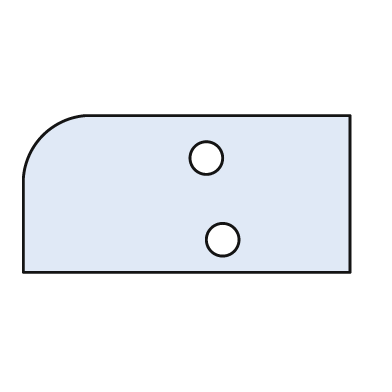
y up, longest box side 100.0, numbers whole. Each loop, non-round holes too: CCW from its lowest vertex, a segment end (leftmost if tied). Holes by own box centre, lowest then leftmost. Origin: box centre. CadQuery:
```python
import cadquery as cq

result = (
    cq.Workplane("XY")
    .moveTo(-50.0, -24.0)
    .lineTo(50.0, -24.0)
    .lineTo(50.0, 24.0)
    .lineTo(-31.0, 24.0)
    .threePointArc((-44.0, 18.0), (-50.0, 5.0))
    .close()
    .moveTo(11.0, -14.0)
    .circle(5.0)
    .moveTo(6.0, 11.0)
    .circle(5.0)
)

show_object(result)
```